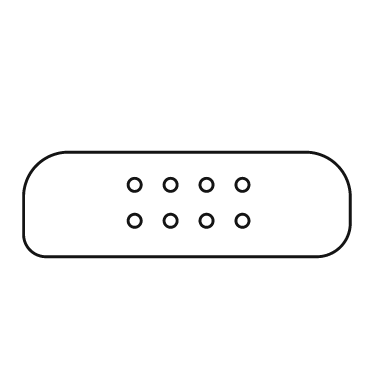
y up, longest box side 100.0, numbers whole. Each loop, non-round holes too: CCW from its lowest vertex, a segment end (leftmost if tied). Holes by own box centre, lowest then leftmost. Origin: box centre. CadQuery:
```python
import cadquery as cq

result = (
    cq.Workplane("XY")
    .moveTo(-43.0, -16.0)
    .lineTo(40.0, -16.0)
    .threePointArc((47.0, -13.0), (50.0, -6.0))
    .lineTo(50.0, 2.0)
    .threePointArc((46.0, 12.0), (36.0, 16.0))
    .lineTo(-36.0, 16.0)
    .threePointArc((-46.0, 12.0), (-50.0, 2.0))
    .lineTo(-50.0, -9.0)
    .threePointArc((-48.0, -14.0), (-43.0, -16.0))
    .close()
    .moveTo(-16.0, -5.0)
    .circle(2.0)
    .moveTo(-5.0, -5.0)
    .circle(2.0)
    .moveTo(6.0, -5.0)
    .circle(2.0)
    .moveTo(17.0, -5.0)
    .circle(2.0)
    .moveTo(-16.0, 6.0)
    .circle(2.0)
    .moveTo(-5.0, 6.0)
    .circle(2.0)
    .moveTo(6.0, 6.0)
    .circle(2.0)
    .moveTo(17.0, 6.0)
    .circle(2.0)
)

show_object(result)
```